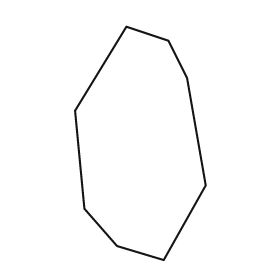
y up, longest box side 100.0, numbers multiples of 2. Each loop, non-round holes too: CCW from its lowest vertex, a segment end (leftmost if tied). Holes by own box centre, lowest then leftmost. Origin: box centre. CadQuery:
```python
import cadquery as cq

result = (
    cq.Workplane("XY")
    .moveTo(10.0, -50.0)
    .lineTo(28.0, -18.0)
    .lineTo(20.0, 28.0)
    .lineTo(12.0, 44.0)
    .lineTo(-6.0, 50.0)
    .lineTo(-28.0, 14.0)
    .lineTo(-24.0, -28.0)
    .lineTo(-10.0, -44.0)
    .close()
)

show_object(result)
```